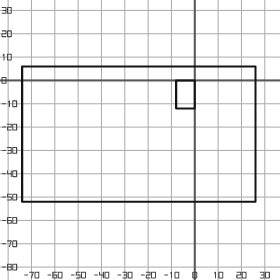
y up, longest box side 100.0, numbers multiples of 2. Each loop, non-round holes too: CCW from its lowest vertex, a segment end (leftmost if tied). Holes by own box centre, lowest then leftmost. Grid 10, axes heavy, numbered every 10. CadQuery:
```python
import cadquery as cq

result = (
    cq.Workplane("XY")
    .moveTo(-74.0, -52.0)
    .lineTo(26.0, -52.0)
    .lineTo(26.0, 6.0)
    .lineTo(-74.0, 6.0)
    .close()
    .moveTo(-8.0, -12.0)
    .lineTo(0.0, -12.0)
    .lineTo(0.0, 0.0)
    .lineTo(-8.0, 0.0)
    .close()
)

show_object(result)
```